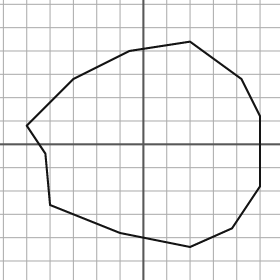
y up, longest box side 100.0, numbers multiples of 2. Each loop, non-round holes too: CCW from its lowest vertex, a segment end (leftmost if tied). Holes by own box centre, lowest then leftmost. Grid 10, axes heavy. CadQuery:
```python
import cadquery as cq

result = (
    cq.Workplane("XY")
    .moveTo(20.0, -44.0)
    .lineTo(38.0, -36.0)
    .lineTo(50.0, -18.0)
    .lineTo(50.0, 12.0)
    .lineTo(42.0, 28.0)
    .lineTo(20.0, 44.0)
    .lineTo(-6.0, 40.0)
    .lineTo(-30.0, 28.0)
    .lineTo(-50.0, 8.0)
    .lineTo(-42.0, -4.0)
    .lineTo(-40.0, -26.0)
    .lineTo(-10.0, -38.0)
    .close()
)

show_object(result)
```